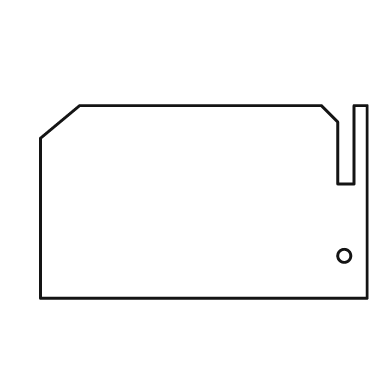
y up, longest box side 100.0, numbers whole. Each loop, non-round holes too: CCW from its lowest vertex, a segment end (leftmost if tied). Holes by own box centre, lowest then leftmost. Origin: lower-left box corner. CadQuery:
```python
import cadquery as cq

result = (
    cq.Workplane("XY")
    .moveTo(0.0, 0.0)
    .lineTo(100.0, 0.0)
    .lineTo(100.0, 59.0)
    .lineTo(96.0, 59.0)
    .lineTo(96.0, 35.0)
    .lineTo(91.0, 35.0)
    .lineTo(91.0, 54.0)
    .lineTo(86.0, 59.0)
    .lineTo(12.0, 59.0)
    .lineTo(0.0, 49.0)
    .close()
    .moveTo(93.0, 13.0)
    .circle(2.0)
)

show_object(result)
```